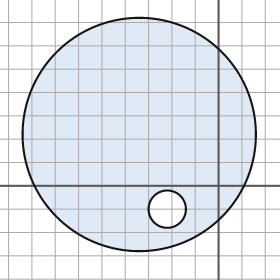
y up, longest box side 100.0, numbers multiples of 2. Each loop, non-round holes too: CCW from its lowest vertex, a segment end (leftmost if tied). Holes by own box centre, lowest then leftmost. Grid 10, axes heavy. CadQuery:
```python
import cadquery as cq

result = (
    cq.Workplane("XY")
    .moveTo(-34.0, 22.0)
    .circle(50.0)
    .moveTo(-22.0, -10.0)
    .circle(8.0)
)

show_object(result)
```